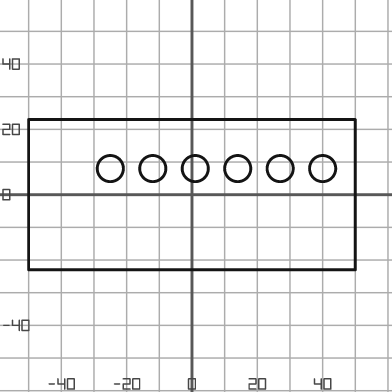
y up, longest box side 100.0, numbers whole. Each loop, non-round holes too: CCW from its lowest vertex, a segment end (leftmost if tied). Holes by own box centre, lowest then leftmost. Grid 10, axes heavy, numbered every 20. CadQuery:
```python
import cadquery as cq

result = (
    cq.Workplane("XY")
    .moveTo(-50.0, -23.0)
    .lineTo(50.0, -23.0)
    .lineTo(50.0, 23.0)
    .lineTo(-50.0, 23.0)
    .close()
    .moveTo(-25.0, 8.0)
    .circle(4.0)
    .moveTo(-12.0, 8.0)
    .circle(4.0)
    .moveTo(1.0, 8.0)
    .circle(4.0)
    .moveTo(14.0, 8.0)
    .circle(4.0)
    .moveTo(27.0, 8.0)
    .circle(4.0)
    .moveTo(40.0, 8.0)
    .circle(4.0)
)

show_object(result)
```